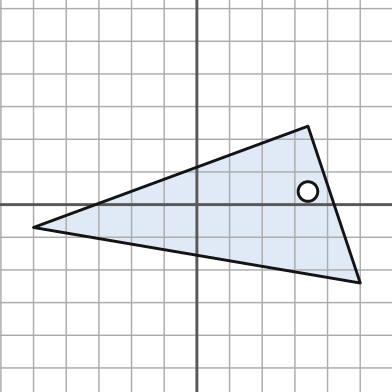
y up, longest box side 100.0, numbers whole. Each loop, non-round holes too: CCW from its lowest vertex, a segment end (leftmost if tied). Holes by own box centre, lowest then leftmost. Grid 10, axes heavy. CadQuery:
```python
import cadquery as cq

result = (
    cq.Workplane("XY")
    .moveTo(50.0, -24.0)
    .lineTo(34.0, 24.0)
    .lineTo(-50.0, -7.0)
    .close()
    .moveTo(34.0, 4.0)
    .circle(3.0)
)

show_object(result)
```